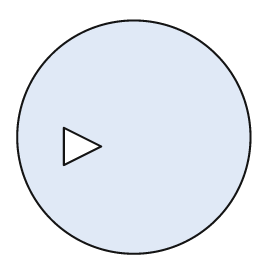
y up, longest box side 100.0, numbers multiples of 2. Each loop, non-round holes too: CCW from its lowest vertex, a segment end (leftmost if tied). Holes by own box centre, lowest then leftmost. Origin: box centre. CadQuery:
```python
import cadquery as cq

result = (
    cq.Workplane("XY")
    .moveTo(0.0, 0.0)
    .circle(50.0)
    .moveTo(-30.0, -12.0)
    .lineTo(-14.0, -4.0)
    .lineTo(-30.0, 4.0)
    .close()
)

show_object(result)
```